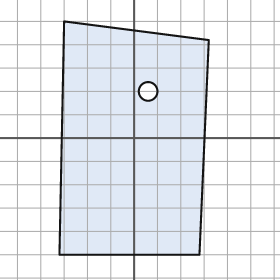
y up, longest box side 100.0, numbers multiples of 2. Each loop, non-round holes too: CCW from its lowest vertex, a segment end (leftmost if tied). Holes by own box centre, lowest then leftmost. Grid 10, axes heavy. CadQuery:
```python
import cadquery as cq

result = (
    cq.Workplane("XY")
    .moveTo(-32.0, -50.0)
    .lineTo(28.0, -50.0)
    .lineTo(32.0, 42.0)
    .lineTo(-30.0, 50.0)
    .close()
    .moveTo(6.0, 20.0)
    .circle(4.0)
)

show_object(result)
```